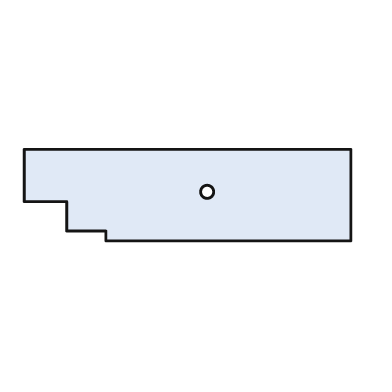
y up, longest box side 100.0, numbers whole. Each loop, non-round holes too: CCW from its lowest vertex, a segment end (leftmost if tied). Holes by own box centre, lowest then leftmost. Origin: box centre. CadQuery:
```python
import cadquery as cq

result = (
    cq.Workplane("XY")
    .moveTo(-25.0, -14.0)
    .lineTo(50.0, -14.0)
    .lineTo(50.0, 14.0)
    .lineTo(-50.0, 14.0)
    .lineTo(-50.0, -2.0)
    .lineTo(-37.0, -2.0)
    .lineTo(-37.0, -11.0)
    .lineTo(-25.0, -11.0)
    .close()
    .moveTo(6.0, 1.0)
    .circle(2.0)
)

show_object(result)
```